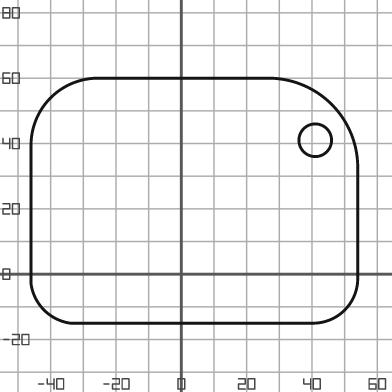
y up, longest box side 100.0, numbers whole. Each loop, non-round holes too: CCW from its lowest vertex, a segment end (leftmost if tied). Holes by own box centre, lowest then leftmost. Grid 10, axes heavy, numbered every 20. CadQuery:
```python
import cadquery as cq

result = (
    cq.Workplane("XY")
    .moveTo(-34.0, -15.0)
    .lineTo(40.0, -15.0)
    .threePointArc((50.0, -11.0), (54.0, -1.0))
    .lineTo(54.0, 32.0)
    .threePointArc((46.0, 52.0), (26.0, 60.0))
    .lineTo(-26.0, 60.0)
    .threePointArc((-40.0, 54.0), (-46.0, 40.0))
    .lineTo(-46.0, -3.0)
    .threePointArc((-42.0, -11.0), (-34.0, -15.0))
    .close()
    .moveTo(41.0, 41.0)
    .circle(5.0)
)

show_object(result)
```